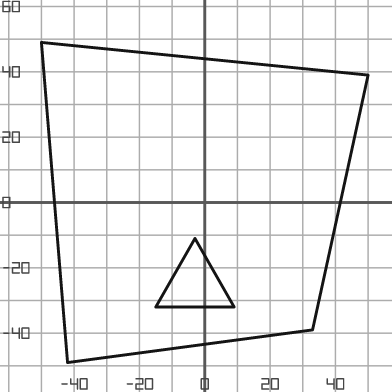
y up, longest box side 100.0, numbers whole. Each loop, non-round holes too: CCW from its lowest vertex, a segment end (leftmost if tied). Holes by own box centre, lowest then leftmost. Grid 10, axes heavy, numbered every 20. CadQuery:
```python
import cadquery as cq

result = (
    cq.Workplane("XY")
    .moveTo(-42.0, -49.0)
    .lineTo(33.0, -39.0)
    .lineTo(50.0, 39.0)
    .lineTo(-50.0, 49.0)
    .close()
    .moveTo(-15.0, -32.0)
    .lineTo(9.0, -32.0)
    .lineTo(-3.0, -11.0)
    .close()
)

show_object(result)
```